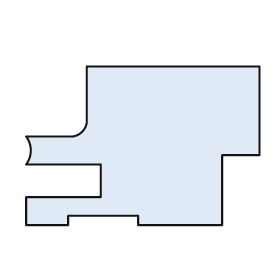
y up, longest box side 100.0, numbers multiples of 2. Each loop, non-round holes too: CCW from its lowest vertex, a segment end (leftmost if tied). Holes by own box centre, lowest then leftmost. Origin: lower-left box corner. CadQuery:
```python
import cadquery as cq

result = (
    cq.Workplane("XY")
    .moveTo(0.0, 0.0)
    .lineTo(18.0, 0.0)
    .lineTo(18.0, 4.0)
    .lineTo(48.0, 4.0)
    .lineTo(48.0, 0.0)
    .lineTo(84.0, 0.0)
    .lineTo(84.0, 30.0)
    .lineTo(100.0, 30.0)
    .lineTo(100.0, 68.0)
    .lineTo(26.0, 68.0)
    .lineTo(26.0, 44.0)
    .threePointArc((24.0, 40.0), (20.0, 38.0))
    .lineTo(0.0, 38.0)
    .threePointArc((2.0, 32.0), (0.0, 26.0))
    .lineTo(32.0, 26.0)
    .lineTo(32.0, 12.0)
    .lineTo(0.0, 12.0)
    .close()
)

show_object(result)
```